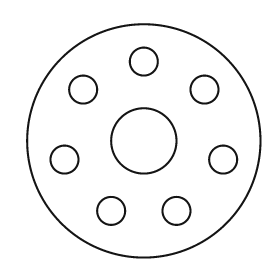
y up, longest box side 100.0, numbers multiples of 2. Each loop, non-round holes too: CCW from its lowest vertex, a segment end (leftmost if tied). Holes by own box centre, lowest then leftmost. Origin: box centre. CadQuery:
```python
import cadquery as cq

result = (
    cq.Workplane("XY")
    .moveTo(0.0, 0.0)
    .circle(50.0)
    .moveTo(-14.0, -30.0)
    .circle(6.0)
    .moveTo(14.0, -30.0)
    .circle(6.0)
    .moveTo(-34.0, -8.0)
    .circle(6.0)
    .moveTo(34.0, -8.0)
    .circle(6.0)
    .moveTo(0.0, 0.0)
    .circle(14.0)
    .moveTo(-26.0, 22.0)
    .circle(6.0)
    .moveTo(26.0, 22.0)
    .circle(6.0)
    .moveTo(0.0, 34.0)
    .circle(6.0)
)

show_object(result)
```